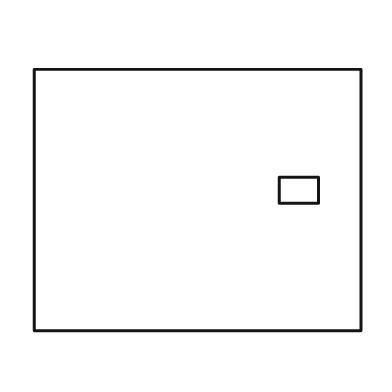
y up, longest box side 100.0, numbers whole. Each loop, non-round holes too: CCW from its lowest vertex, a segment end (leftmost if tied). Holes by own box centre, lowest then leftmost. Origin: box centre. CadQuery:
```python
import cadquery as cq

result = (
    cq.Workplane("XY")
    .moveTo(-50.0, -40.0)
    .lineTo(50.0, -40.0)
    .lineTo(50.0, 40.0)
    .lineTo(-50.0, 40.0)
    .close()
    .moveTo(25.0, -1.0)
    .lineTo(37.0, -1.0)
    .lineTo(37.0, 7.0)
    .lineTo(25.0, 7.0)
    .close()
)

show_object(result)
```